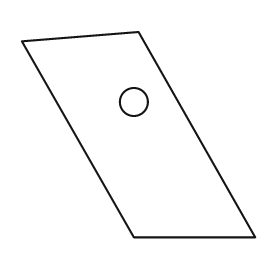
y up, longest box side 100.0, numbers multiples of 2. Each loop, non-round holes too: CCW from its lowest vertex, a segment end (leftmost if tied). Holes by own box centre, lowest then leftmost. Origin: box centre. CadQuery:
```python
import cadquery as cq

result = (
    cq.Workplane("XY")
    .moveTo(-2.0, -44.0)
    .lineTo(50.0, -44.0)
    .lineTo(0.0, 44.0)
    .lineTo(-50.0, 40.0)
    .close()
    .moveTo(-2.0, 14.0)
    .circle(6.0)
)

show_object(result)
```